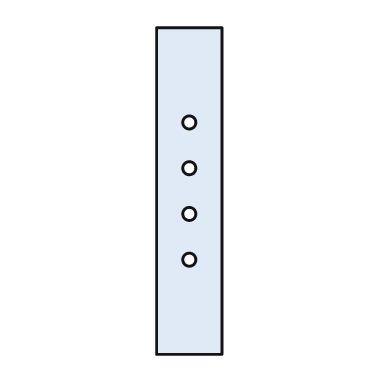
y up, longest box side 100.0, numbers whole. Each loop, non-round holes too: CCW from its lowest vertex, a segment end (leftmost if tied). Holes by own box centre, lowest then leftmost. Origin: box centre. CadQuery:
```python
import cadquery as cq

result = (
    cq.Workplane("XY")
    .moveTo(-10.0, -50.0)
    .lineTo(10.0, -50.0)
    .lineTo(10.0, 50.0)
    .lineTo(-10.0, 50.0)
    .close()
    .moveTo(0.0, -21.0)
    .circle(2.0)
    .moveTo(0.0, -7.0)
    .circle(2.0)
    .moveTo(0.0, 7.0)
    .circle(2.0)
    .moveTo(0.0, 21.0)
    .circle(2.0)
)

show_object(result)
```